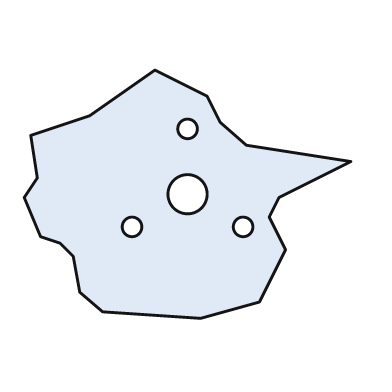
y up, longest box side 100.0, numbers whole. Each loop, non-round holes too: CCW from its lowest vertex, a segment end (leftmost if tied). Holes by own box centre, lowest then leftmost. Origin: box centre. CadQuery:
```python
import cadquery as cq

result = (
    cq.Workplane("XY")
    .moveTo(4.0, -38.0)
    .lineTo(22.0, -33.0)
    .lineTo(30.0, -17.0)
    .lineTo(25.0, -7.0)
    .lineTo(28.0, -1.0)
    .lineTo(50.0, 10.0)
    .lineTo(18.0, 15.0)
    .lineTo(10.0, 22.0)
    .lineTo(6.0, 30.0)
    .lineTo(-10.0, 38.0)
    .lineTo(-30.0, 24.0)
    .lineTo(-48.0, 18.0)
    .lineTo(-46.0, 5.0)
    .lineTo(-50.0, -1.0)
    .lineTo(-45.0, -13.0)
    .lineTo(-39.0, -15.0)
    .lineTo(-35.0, -19.0)
    .lineTo(-33.0, -30.0)
    .lineTo(-26.0, -36.0)
    .close()
    .moveTo(-17.0, -10.0)
    .circle(3.0)
    .moveTo(17.0, -10.0)
    .circle(3.0)
    .moveTo(0.0, 0.0)
    .circle(6.0)
    .moveTo(0.0, 20.0)
    .circle(3.0)
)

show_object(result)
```